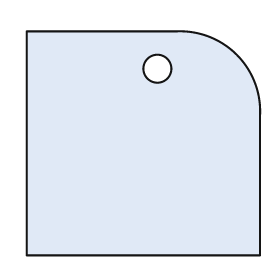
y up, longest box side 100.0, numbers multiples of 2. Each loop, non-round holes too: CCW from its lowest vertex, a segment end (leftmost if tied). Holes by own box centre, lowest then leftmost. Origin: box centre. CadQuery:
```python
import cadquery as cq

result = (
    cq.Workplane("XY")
    .moveTo(-50.0, -48.0)
    .lineTo(50.0, -48.0)
    .lineTo(50.0, 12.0)
    .threePointArc((40.0, 38.0), (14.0, 48.0))
    .lineTo(-50.0, 48.0)
    .close()
    .moveTo(6.0, 32.0)
    .circle(6.0)
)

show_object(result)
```